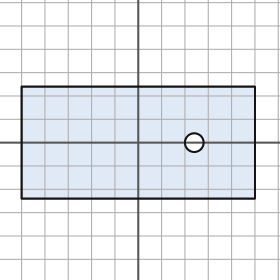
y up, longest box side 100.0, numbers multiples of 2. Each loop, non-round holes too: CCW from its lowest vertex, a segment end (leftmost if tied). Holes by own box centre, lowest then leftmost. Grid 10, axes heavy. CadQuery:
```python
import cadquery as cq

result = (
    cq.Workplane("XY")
    .moveTo(-50.0, -24.0)
    .lineTo(50.0, -24.0)
    .lineTo(50.0, 24.0)
    .lineTo(-50.0, 24.0)
    .close()
    .moveTo(24.0, 0.0)
    .circle(4.0)
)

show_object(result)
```